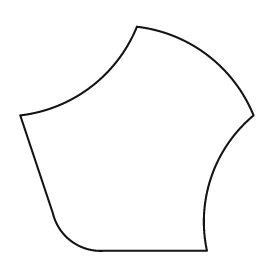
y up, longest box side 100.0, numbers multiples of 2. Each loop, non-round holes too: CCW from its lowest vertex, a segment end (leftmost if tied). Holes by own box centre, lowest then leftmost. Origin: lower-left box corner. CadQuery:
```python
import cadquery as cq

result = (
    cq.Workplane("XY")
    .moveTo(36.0, 0.0)
    .lineTo(80.0, 0.0)
    .threePointArc((82.0, 32.0), (100.0, 58.0))
    .threePointArc((80.0, 84.0), (50.0, 96.0))
    .threePointArc((30.0, 70.0), (0.0, 58.0))
    .lineTo(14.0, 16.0)
    .threePointArc((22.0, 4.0), (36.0, 0.0))
    .close()
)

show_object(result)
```